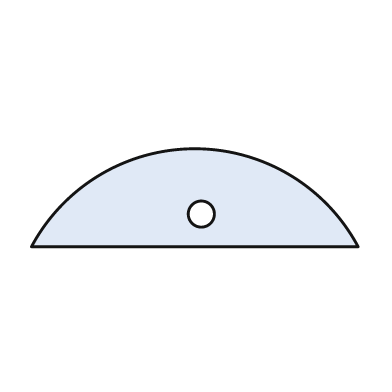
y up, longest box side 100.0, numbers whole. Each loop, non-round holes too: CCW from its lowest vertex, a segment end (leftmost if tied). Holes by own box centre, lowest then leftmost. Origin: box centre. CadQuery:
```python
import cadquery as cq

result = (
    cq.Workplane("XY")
    .moveTo(-50.0, -15.0)
    .lineTo(50.0, -15.0)
    .threePointArc((0.0, 15.0), (-50.0, -15.0))
    .close()
    .moveTo(2.0, -5.0)
    .circle(4.0)
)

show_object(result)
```